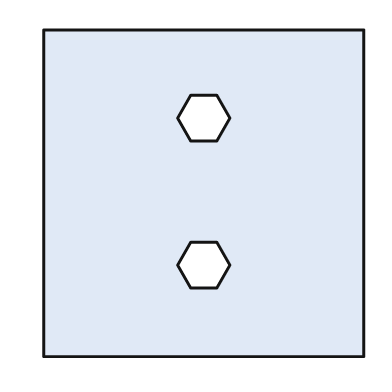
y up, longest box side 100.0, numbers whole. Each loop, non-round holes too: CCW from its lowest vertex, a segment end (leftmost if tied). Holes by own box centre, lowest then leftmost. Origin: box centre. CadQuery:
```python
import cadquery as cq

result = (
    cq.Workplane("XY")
    .moveTo(-49.0, -50.0)
    .lineTo(49.0, -50.0)
    .lineTo(49.0, 50.0)
    .lineTo(-49.0, 50.0)
    .close()
    .moveTo(-4.0, -29.0)
    .lineTo(4.0, -29.0)
    .lineTo(8.0, -22.0)
    .lineTo(4.0, -15.0)
    .lineTo(-4.0, -15.0)
    .lineTo(-8.0, -22.0)
    .close()
    .moveTo(-4.0, 16.0)
    .lineTo(4.0, 16.0)
    .lineTo(8.0, 23.0)
    .lineTo(4.0, 30.0)
    .lineTo(-4.0, 30.0)
    .lineTo(-8.0, 23.0)
    .close()
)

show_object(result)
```